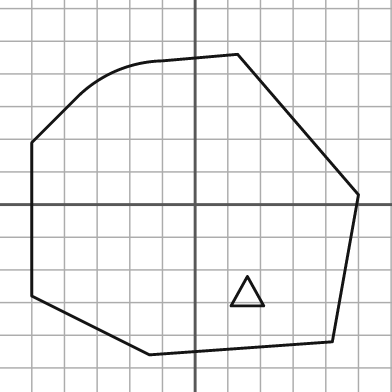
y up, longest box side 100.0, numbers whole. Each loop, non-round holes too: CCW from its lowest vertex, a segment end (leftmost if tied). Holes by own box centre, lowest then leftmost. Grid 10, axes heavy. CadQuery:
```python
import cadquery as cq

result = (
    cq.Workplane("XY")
    .moveTo(-14.0, -46.0)
    .lineTo(42.0, -42.0)
    .lineTo(50.0, 3.0)
    .lineTo(13.0, 46.0)
    .lineTo(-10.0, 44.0)
    .threePointArc((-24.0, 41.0), (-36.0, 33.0))
    .lineTo(-50.0, 19.0)
    .lineTo(-50.0, -28.0)
    .close()
    .moveTo(11.0, -31.0)
    .lineTo(21.0, -31.0)
    .lineTo(16.0, -22.0)
    .close()
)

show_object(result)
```